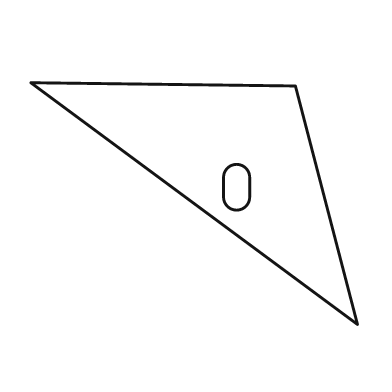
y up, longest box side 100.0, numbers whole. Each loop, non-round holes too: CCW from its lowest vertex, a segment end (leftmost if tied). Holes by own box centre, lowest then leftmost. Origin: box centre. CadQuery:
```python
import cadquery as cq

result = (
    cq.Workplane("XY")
    .moveTo(50.0, -37.0)
    .lineTo(31.0, 36.0)
    .lineTo(-50.0, 37.0)
    .close()
    .moveTo(9.0, 2.0)
    .threePointArc((13.0, -2.0), (17.0, 2.0))
    .lineTo(17.0, 8.0)
    .threePointArc((13.0, 12.0), (9.0, 8.0))
    .close()
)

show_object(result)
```